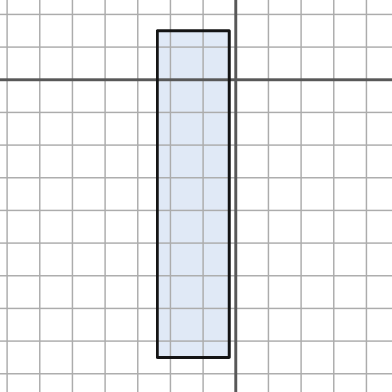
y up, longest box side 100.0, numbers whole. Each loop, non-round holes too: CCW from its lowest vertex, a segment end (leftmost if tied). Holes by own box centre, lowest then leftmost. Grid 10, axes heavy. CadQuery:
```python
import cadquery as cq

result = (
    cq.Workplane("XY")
    .moveTo(-24.0, -85.0)
    .lineTo(-2.0, -85.0)
    .lineTo(-2.0, 15.0)
    .lineTo(-24.0, 15.0)
    .close()
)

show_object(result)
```